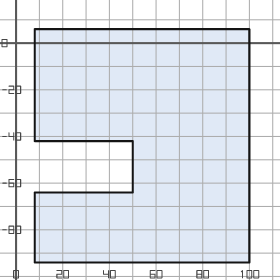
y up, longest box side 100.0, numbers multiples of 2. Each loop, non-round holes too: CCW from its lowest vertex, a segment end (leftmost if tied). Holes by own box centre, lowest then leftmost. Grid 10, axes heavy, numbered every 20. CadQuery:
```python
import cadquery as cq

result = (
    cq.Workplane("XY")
    .moveTo(8.0, -94.0)
    .lineTo(100.0, -94.0)
    .lineTo(100.0, 6.0)
    .lineTo(8.0, 6.0)
    .lineTo(8.0, -42.0)
    .lineTo(50.0, -42.0)
    .lineTo(50.0, -64.0)
    .lineTo(8.0, -64.0)
    .close()
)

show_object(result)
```